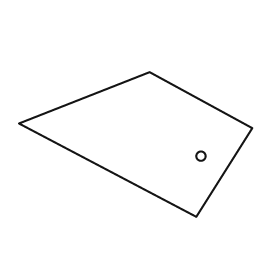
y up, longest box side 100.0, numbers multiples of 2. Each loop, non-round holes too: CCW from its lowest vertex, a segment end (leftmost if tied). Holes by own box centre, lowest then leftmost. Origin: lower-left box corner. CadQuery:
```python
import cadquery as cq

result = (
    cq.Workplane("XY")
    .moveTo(76.0, 0.0)
    .lineTo(100.0, 38.0)
    .lineTo(56.0, 62.0)
    .lineTo(0.0, 40.0)
    .close()
    .moveTo(78.0, 26.0)
    .circle(2.0)
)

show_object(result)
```